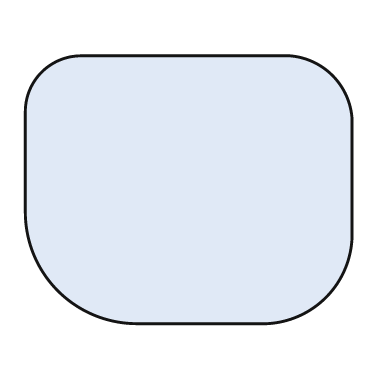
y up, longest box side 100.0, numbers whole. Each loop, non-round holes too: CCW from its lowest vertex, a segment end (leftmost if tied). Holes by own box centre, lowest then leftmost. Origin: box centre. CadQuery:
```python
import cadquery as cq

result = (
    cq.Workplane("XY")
    .moveTo(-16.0, -41.0)
    .lineTo(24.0, -41.0)
    .threePointArc((42.0, -33.0), (50.0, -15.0))
    .lineTo(50.0, 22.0)
    .threePointArc((44.0, 35.0), (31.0, 41.0))
    .lineTo(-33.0, 41.0)
    .threePointArc((-45.0, 36.0), (-50.0, 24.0))
    .lineTo(-50.0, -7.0)
    .threePointArc((-40.0, -31.0), (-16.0, -41.0))
    .close()
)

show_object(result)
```